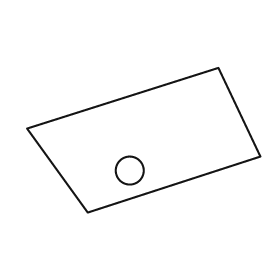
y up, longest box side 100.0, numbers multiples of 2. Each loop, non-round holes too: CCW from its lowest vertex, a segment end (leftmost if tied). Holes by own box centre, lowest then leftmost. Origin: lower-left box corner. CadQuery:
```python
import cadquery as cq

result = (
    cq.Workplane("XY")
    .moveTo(26.0, 0.0)
    .lineTo(100.0, 24.0)
    .lineTo(82.0, 62.0)
    .lineTo(0.0, 36.0)
    .close()
    .moveTo(44.0, 18.0)
    .circle(6.0)
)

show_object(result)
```